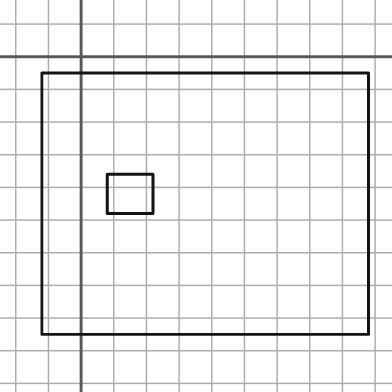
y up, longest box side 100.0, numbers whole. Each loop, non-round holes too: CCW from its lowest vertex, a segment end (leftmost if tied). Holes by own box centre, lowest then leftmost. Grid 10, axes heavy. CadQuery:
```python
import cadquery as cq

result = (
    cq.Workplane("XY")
    .moveTo(-12.0, -85.0)
    .lineTo(88.0, -85.0)
    .lineTo(88.0, -5.0)
    .lineTo(-12.0, -5.0)
    .close()
    .moveTo(8.0, -48.0)
    .lineTo(22.0, -48.0)
    .lineTo(22.0, -36.0)
    .lineTo(8.0, -36.0)
    .close()
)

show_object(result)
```